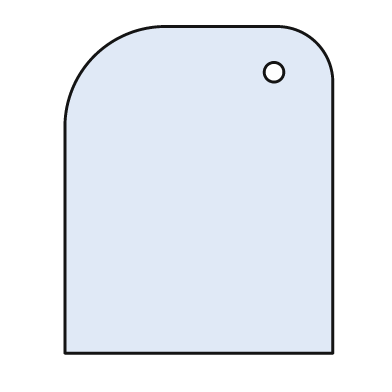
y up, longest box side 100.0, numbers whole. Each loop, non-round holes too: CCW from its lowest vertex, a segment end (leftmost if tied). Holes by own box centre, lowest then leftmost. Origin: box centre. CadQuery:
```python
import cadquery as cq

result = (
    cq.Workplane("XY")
    .moveTo(-41.0, -50.0)
    .lineTo(41.0, -50.0)
    .lineTo(41.0, 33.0)
    .threePointArc((36.0, 45.0), (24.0, 50.0))
    .lineTo(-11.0, 50.0)
    .threePointArc((-32.0, 41.0), (-41.0, 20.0))
    .close()
    .moveTo(23.0, 36.0)
    .circle(3.0)
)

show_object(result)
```